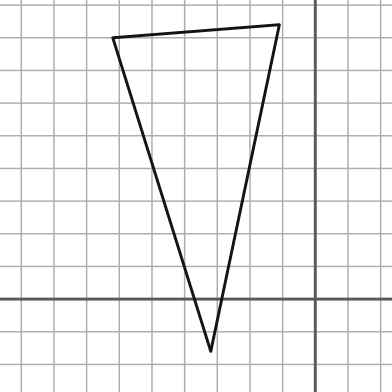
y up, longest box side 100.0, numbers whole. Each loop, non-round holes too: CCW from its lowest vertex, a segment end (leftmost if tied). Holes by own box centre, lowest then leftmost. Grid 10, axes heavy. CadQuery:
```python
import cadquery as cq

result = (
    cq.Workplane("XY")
    .moveTo(-32.0, -16.0)
    .lineTo(-11.0, 84.0)
    .lineTo(-62.0, 80.0)
    .close()
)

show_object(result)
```